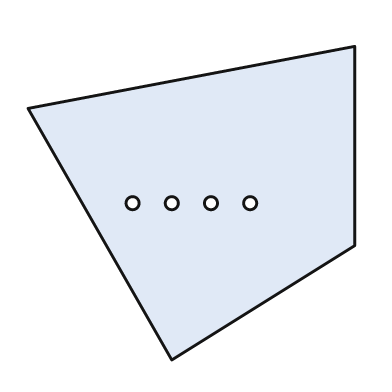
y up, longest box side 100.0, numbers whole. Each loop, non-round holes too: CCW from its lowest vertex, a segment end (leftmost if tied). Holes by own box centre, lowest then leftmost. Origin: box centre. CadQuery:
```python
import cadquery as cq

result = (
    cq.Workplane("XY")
    .moveTo(-6.0, -48.0)
    .lineTo(50.0, -13.0)
    .lineTo(50.0, 48.0)
    .lineTo(-50.0, 29.0)
    .close()
    .moveTo(-18.0, 0.0)
    .circle(2.0)
    .moveTo(-6.0, 0.0)
    .circle(2.0)
    .moveTo(6.0, 0.0)
    .circle(2.0)
    .moveTo(18.0, 0.0)
    .circle(2.0)
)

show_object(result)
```